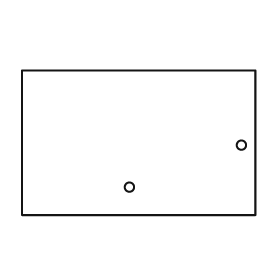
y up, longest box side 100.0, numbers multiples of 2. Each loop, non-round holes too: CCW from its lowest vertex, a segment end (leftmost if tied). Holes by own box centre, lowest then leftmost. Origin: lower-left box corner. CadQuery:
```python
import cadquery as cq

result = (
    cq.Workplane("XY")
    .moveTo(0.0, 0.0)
    .lineTo(100.0, 0.0)
    .lineTo(100.0, 62.0)
    .lineTo(0.0, 62.0)
    .close()
    .moveTo(46.0, 12.0)
    .circle(2.0)
    .moveTo(94.0, 30.0)
    .circle(2.0)
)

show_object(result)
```